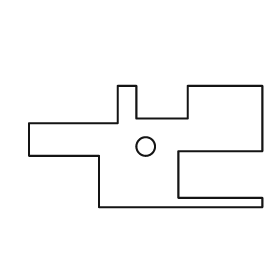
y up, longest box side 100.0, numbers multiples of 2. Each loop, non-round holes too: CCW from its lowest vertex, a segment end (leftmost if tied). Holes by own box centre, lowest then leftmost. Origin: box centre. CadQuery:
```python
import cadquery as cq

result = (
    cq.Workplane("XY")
    .moveTo(-20.0, -26.0)
    .lineTo(50.0, -26.0)
    .lineTo(50.0, -22.0)
    .lineTo(14.0, -22.0)
    .lineTo(14.0, -2.0)
    .lineTo(50.0, -2.0)
    .lineTo(50.0, 26.0)
    .lineTo(18.0, 26.0)
    .lineTo(18.0, 12.0)
    .lineTo(-4.0, 12.0)
    .lineTo(-4.0, 26.0)
    .lineTo(-12.0, 26.0)
    .lineTo(-12.0, 10.0)
    .lineTo(-50.0, 10.0)
    .lineTo(-50.0, -4.0)
    .lineTo(-20.0, -4.0)
    .close()
    .moveTo(0.0, 0.0)
    .circle(4.0)
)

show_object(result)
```